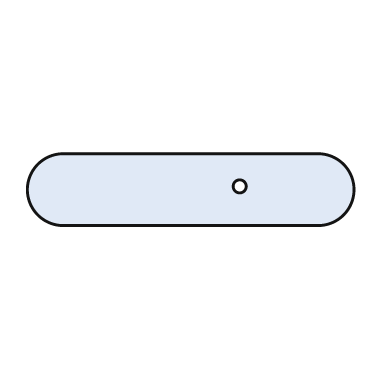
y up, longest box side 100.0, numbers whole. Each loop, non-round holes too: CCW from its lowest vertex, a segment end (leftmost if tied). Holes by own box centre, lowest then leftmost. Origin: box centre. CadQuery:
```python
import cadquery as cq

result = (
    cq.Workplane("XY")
    .moveTo(-39.0, -11.0)
    .lineTo(39.0, -11.0)
    .threePointArc((50.0, 0.0), (39.0, 11.0))
    .lineTo(-39.0, 11.0)
    .threePointArc((-50.0, 0.0), (-39.0, -11.0))
    .close()
    .moveTo(15.0, 1.0)
    .circle(2.0)
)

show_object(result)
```